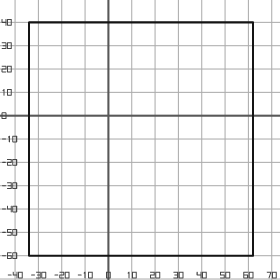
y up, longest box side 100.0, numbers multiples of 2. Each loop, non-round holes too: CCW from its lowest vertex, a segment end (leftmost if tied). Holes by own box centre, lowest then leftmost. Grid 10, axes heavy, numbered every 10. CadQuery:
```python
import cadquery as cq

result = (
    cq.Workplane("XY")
    .moveTo(-34.0, -60.0)
    .lineTo(62.0, -60.0)
    .lineTo(62.0, 40.0)
    .lineTo(-34.0, 40.0)
    .close()
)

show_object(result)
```